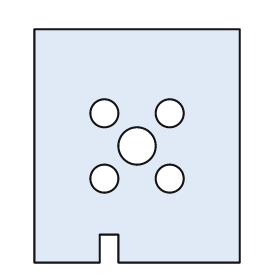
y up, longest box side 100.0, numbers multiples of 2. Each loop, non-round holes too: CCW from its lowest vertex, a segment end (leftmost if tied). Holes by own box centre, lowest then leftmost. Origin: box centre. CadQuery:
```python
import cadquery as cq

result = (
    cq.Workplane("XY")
    .moveTo(-44.0, -50.0)
    .lineTo(-16.0, -50.0)
    .lineTo(-16.0, -38.0)
    .lineTo(-8.0, -38.0)
    .lineTo(-8.0, -50.0)
    .lineTo(44.0, -50.0)
    .lineTo(44.0, 50.0)
    .lineTo(-44.0, 50.0)
    .close()
    .moveTo(-14.0, -14.0)
    .circle(6.0)
    .moveTo(14.0, -14.0)
    .circle(6.0)
    .moveTo(0.0, 0.0)
    .circle(8.0)
    .moveTo(-14.0, 14.0)
    .circle(6.0)
    .moveTo(14.0, 14.0)
    .circle(6.0)
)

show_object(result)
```